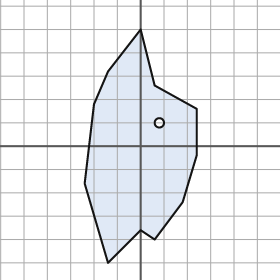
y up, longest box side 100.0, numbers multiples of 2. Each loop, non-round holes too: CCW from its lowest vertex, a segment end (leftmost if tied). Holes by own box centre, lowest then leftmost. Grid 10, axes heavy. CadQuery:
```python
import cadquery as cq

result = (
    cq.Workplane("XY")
    .moveTo(-14.0, -50.0)
    .lineTo(0.0, -36.0)
    .lineTo(6.0, -40.0)
    .lineTo(18.0, -24.0)
    .lineTo(24.0, -4.0)
    .lineTo(24.0, 16.0)
    .lineTo(6.0, 26.0)
    .lineTo(0.0, 50.0)
    .lineTo(-14.0, 32.0)
    .lineTo(-20.0, 18.0)
    .lineTo(-24.0, -16.0)
    .close()
    .moveTo(8.0, 10.0)
    .circle(2.0)
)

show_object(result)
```